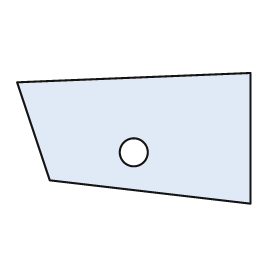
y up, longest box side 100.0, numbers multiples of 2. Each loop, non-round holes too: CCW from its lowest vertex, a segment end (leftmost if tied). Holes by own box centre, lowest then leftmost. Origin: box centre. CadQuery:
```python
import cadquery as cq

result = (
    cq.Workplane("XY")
    .moveTo(50.0, -28.0)
    .lineTo(50.0, 28.0)
    .lineTo(-50.0, 24.0)
    .lineTo(-36.0, -18.0)
    .close()
    .moveTo(0.0, -6.0)
    .circle(6.0)
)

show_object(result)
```